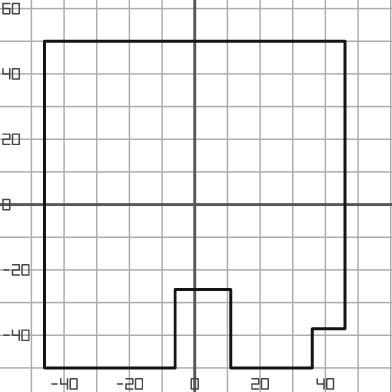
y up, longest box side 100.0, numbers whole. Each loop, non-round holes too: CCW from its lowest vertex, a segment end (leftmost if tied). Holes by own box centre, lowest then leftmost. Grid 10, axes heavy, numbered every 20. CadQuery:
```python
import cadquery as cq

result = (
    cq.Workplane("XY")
    .moveTo(-46.0, -50.0)
    .lineTo(-6.0, -50.0)
    .lineTo(-6.0, -26.0)
    .lineTo(11.0, -26.0)
    .lineTo(11.0, -50.0)
    .lineTo(36.0, -50.0)
    .lineTo(36.0, -38.0)
    .lineTo(46.0, -38.0)
    .lineTo(46.0, 50.0)
    .lineTo(-46.0, 50.0)
    .close()
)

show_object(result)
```